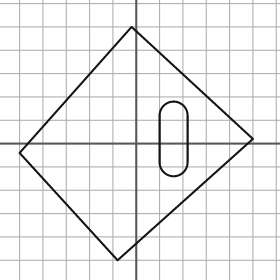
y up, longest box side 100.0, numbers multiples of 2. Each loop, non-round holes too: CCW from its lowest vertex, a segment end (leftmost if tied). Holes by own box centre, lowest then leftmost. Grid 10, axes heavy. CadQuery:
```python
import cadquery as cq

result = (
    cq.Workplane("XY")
    .moveTo(-8.0, -50.0)
    .lineTo(50.0, 2.0)
    .lineTo(-2.0, 50.0)
    .lineTo(-50.0, -4.0)
    .close()
    .moveTo(10.0, -8.0)
    .threePointArc((16.0, -14.0), (22.0, -8.0))
    .lineTo(22.0, 12.0)
    .threePointArc((16.0, 18.0), (10.0, 12.0))
    .close()
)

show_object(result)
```